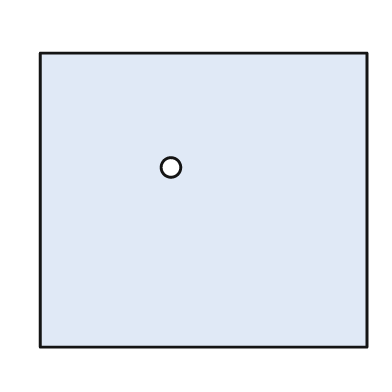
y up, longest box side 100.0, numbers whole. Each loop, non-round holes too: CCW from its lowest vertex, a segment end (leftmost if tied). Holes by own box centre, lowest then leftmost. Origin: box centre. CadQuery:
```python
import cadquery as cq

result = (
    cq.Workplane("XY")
    .moveTo(-50.0, -45.0)
    .lineTo(50.0, -45.0)
    .lineTo(50.0, 45.0)
    .lineTo(-50.0, 45.0)
    .close()
    .moveTo(-10.0, 10.0)
    .circle(3.0)
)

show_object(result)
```